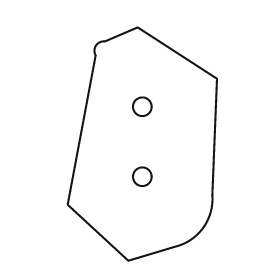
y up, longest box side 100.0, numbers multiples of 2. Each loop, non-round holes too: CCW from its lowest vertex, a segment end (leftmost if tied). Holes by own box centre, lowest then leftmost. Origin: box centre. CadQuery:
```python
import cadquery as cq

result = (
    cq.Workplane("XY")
    .moveTo(-6.0, -50.0)
    .lineTo(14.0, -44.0)
    .threePointArc((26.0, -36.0), (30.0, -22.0))
    .lineTo(32.0, 28.0)
    .lineTo(-2.0, 50.0)
    .lineTo(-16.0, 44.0)
    .threePointArc((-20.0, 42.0), (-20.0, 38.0))
    .lineTo(-32.0, -26.0)
    .close()
    .moveTo(0.0, -14.0)
    .circle(4.0)
    .moveTo(0.0, 16.0)
    .circle(4.0)
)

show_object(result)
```